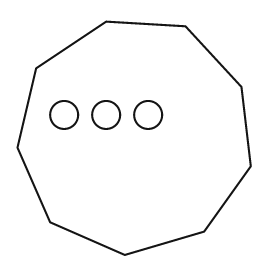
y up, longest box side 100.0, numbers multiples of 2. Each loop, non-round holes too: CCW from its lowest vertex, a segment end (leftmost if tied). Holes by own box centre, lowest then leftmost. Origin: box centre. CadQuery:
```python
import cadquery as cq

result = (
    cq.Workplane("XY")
    .moveTo(-4.0, -50.0)
    .lineTo(30.0, -40.0)
    .lineTo(50.0, -12.0)
    .lineTo(46.0, 22.0)
    .lineTo(22.0, 48.0)
    .lineTo(-12.0, 50.0)
    .lineTo(-42.0, 30.0)
    .lineTo(-50.0, -4.0)
    .lineTo(-36.0, -36.0)
    .close()
    .moveTo(-30.0, 10.0)
    .circle(6.0)
    .moveTo(-12.0, 10.0)
    .circle(6.0)
    .moveTo(6.0, 10.0)
    .circle(6.0)
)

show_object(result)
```